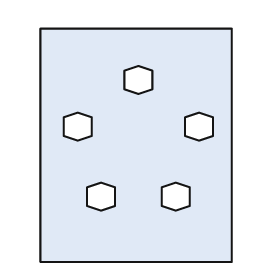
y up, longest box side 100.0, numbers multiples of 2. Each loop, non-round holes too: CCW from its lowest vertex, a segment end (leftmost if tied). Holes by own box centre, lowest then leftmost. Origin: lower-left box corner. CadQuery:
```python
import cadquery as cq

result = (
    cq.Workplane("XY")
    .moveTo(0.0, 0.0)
    .lineTo(82.0, 0.0)
    .lineTo(82.0, 100.0)
    .lineTo(0.0, 100.0)
    .close()
    .moveTo(26.0, 22.0)
    .lineTo(32.0, 24.0)
    .lineTo(32.0, 32.0)
    .lineTo(26.0, 34.0)
    .lineTo(20.0, 32.0)
    .lineTo(20.0, 24.0)
    .close()
    .moveTo(58.0, 22.0)
    .lineTo(64.0, 24.0)
    .lineTo(64.0, 32.0)
    .lineTo(58.0, 34.0)
    .lineTo(52.0, 32.0)
    .lineTo(52.0, 24.0)
    .close()
    .moveTo(16.0, 52.0)
    .lineTo(22.0, 54.0)
    .lineTo(22.0, 62.0)
    .lineTo(16.0, 64.0)
    .lineTo(10.0, 62.0)
    .lineTo(10.0, 54.0)
    .close()
    .moveTo(68.0, 52.0)
    .lineTo(74.0, 54.0)
    .lineTo(74.0, 62.0)
    .lineTo(68.0, 64.0)
    .lineTo(62.0, 62.0)
    .lineTo(62.0, 54.0)
    .close()
    .moveTo(42.0, 72.0)
    .lineTo(48.0, 74.0)
    .lineTo(48.0, 82.0)
    .lineTo(42.0, 84.0)
    .lineTo(36.0, 82.0)
    .lineTo(36.0, 74.0)
    .close()
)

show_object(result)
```